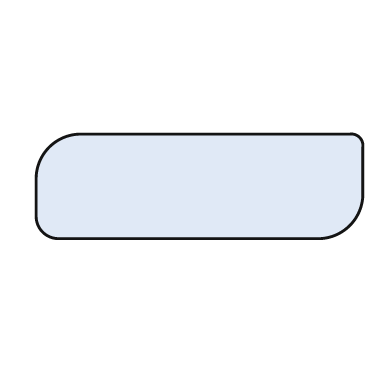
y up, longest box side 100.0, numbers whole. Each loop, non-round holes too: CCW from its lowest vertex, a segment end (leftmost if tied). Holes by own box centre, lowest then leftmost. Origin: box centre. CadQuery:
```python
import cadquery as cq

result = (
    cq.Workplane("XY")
    .moveTo(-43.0, -16.0)
    .lineTo(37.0, -16.0)
    .threePointArc((46.0, -12.0), (50.0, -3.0))
    .lineTo(50.0, 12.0)
    .threePointArc((49.0, 15.0), (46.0, 16.0))
    .lineTo(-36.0, 16.0)
    .threePointArc((-46.0, 12.0), (-50.0, 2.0))
    .lineTo(-50.0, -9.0)
    .threePointArc((-48.0, -14.0), (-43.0, -16.0))
    .close()
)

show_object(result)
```